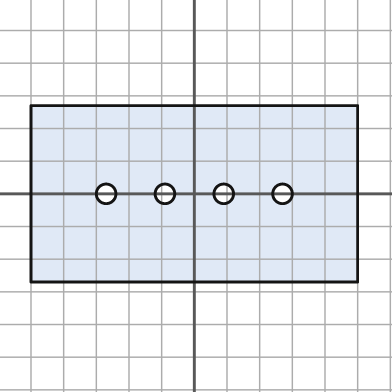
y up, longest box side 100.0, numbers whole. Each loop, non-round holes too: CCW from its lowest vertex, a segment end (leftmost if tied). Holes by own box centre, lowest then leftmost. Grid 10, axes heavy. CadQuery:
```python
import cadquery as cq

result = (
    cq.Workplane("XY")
    .moveTo(-50.0, -27.0)
    .lineTo(50.0, -27.0)
    .lineTo(50.0, 27.0)
    .lineTo(-50.0, 27.0)
    .close()
    .moveTo(-27.0, 0.0)
    .circle(3.0)
    .moveTo(-9.0, 0.0)
    .circle(3.0)
    .moveTo(9.0, 0.0)
    .circle(3.0)
    .moveTo(27.0, 0.0)
    .circle(3.0)
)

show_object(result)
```